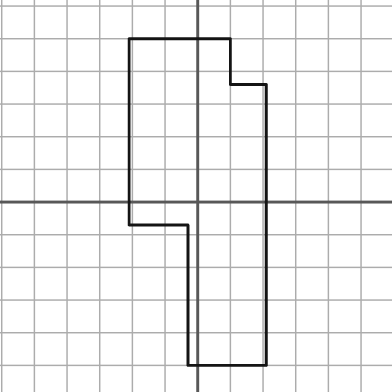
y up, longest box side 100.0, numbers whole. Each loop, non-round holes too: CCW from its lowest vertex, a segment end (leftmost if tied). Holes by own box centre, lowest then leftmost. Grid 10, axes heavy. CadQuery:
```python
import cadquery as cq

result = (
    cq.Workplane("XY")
    .moveTo(-3.0, -50.0)
    .lineTo(21.0, -50.0)
    .lineTo(21.0, 36.0)
    .lineTo(10.0, 36.0)
    .lineTo(10.0, 50.0)
    .lineTo(-21.0, 50.0)
    .lineTo(-21.0, -7.0)
    .lineTo(-3.0, -7.0)
    .close()
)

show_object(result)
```